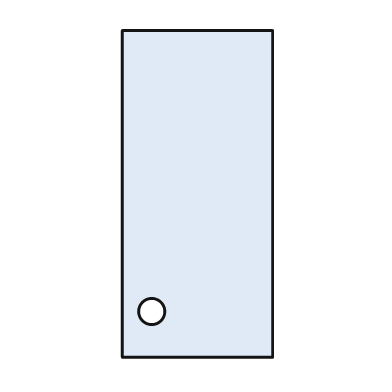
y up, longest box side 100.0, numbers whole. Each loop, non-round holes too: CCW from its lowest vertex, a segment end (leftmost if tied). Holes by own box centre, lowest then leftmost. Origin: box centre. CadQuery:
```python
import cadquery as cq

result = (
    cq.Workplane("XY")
    .moveTo(-23.0, -50.0)
    .lineTo(23.0, -50.0)
    .lineTo(23.0, 50.0)
    .lineTo(-23.0, 50.0)
    .close()
    .moveTo(-14.0, -36.0)
    .circle(4.0)
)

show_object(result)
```